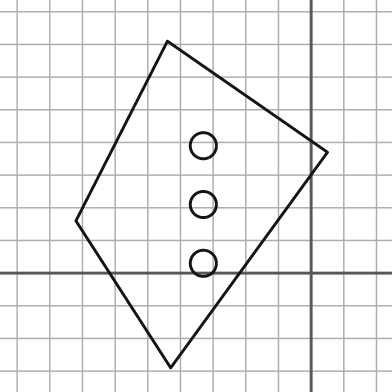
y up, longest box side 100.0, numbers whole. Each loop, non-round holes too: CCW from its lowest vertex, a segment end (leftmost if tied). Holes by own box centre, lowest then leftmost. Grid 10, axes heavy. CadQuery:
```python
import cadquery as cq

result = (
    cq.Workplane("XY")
    .moveTo(-43.0, -29.0)
    .lineTo(5.0, 37.0)
    .lineTo(-44.0, 71.0)
    .lineTo(-72.0, 16.0)
    .close()
    .moveTo(-33.0, 3.0)
    .circle(4.0)
    .moveTo(-33.0, 21.0)
    .circle(4.0)
    .moveTo(-33.0, 39.0)
    .circle(4.0)
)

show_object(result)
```